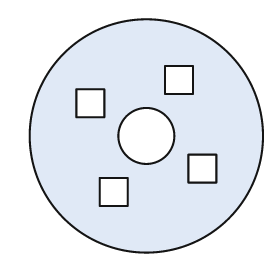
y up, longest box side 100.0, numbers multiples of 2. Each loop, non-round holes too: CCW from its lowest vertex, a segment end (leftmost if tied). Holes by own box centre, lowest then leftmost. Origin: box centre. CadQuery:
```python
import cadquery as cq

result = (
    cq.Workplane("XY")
    .moveTo(0.0, 0.0)
    .circle(50.0)
    .moveTo(-20.0, -30.0)
    .lineTo(-8.0, -30.0)
    .lineTo(-8.0, -18.0)
    .lineTo(-20.0, -18.0)
    .close()
    .moveTo(18.0, -20.0)
    .lineTo(30.0, -20.0)
    .lineTo(30.0, -8.0)
    .lineTo(18.0, -8.0)
    .close()
    .moveTo(0.0, 0.0)
    .circle(12.0)
    .moveTo(-30.0, 8.0)
    .lineTo(-18.0, 8.0)
    .lineTo(-18.0, 20.0)
    .lineTo(-30.0, 20.0)
    .close()
    .moveTo(8.0, 18.0)
    .lineTo(20.0, 18.0)
    .lineTo(20.0, 30.0)
    .lineTo(8.0, 30.0)
    .close()
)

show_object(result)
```